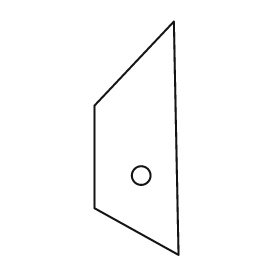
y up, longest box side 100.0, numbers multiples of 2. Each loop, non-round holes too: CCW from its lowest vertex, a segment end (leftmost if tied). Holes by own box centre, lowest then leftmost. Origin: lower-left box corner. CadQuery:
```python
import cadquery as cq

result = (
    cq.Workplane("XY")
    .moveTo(36.0, 0.0)
    .lineTo(34.0, 100.0)
    .lineTo(0.0, 64.0)
    .lineTo(0.0, 20.0)
    .close()
    .moveTo(20.0, 34.0)
    .circle(4.0)
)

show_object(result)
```